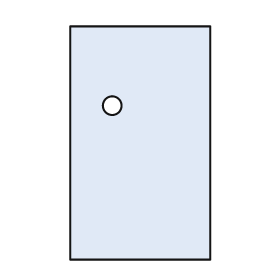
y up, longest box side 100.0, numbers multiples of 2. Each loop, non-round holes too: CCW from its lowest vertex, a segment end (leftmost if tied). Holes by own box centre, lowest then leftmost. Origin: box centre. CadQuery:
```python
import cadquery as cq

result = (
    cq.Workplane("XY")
    .moveTo(-30.0, -50.0)
    .lineTo(30.0, -50.0)
    .lineTo(30.0, 50.0)
    .lineTo(-30.0, 50.0)
    .close()
    .moveTo(-12.0, 16.0)
    .circle(4.0)
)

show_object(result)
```